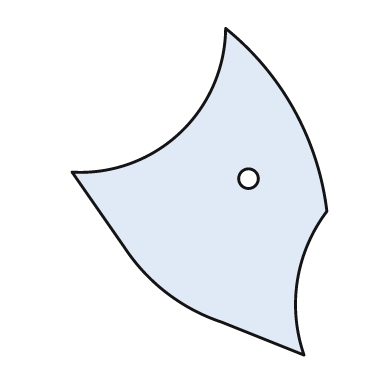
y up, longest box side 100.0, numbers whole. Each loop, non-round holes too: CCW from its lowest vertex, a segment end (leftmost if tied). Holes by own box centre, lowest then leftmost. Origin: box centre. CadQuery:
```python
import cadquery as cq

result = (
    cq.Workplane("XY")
    .moveTo(32.0, -50.0)
    .threePointArc((30.0, -27.0), (39.0, -6.0))
    .threePointArc((29.0, 25.0), (8.0, 50.0))
    .threePointArc((-6.0, 18.0), (-39.0, 6.0))
    .lineTo(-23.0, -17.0)
    .threePointArc((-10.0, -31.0), (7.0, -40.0))
    .close()
    .moveTo(15.0, 4.0)
    .circle(3.0)
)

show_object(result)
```